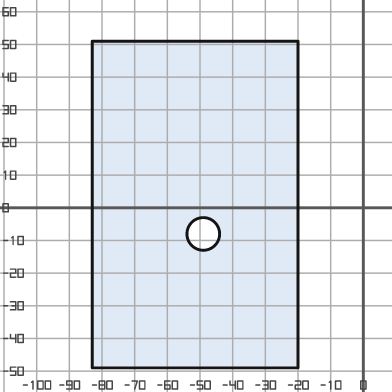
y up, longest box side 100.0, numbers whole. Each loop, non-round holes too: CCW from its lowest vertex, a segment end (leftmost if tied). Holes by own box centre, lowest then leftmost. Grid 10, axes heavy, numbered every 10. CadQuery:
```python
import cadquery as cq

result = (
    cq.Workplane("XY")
    .moveTo(-83.0, -49.0)
    .lineTo(-20.0, -49.0)
    .lineTo(-20.0, 51.0)
    .lineTo(-83.0, 51.0)
    .close()
    .moveTo(-49.0, -8.0)
    .circle(5.0)
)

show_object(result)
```